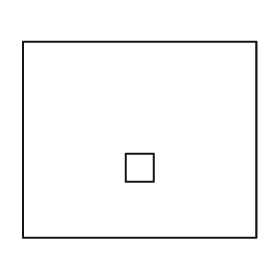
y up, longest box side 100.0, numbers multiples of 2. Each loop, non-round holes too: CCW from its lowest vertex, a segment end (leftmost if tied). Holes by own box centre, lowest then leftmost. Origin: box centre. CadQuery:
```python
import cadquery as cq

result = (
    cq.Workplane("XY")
    .moveTo(-50.0, -42.0)
    .lineTo(50.0, -42.0)
    .lineTo(50.0, 42.0)
    .lineTo(-50.0, 42.0)
    .close()
    .moveTo(-6.0, -18.0)
    .lineTo(6.0, -18.0)
    .lineTo(6.0, -6.0)
    .lineTo(-6.0, -6.0)
    .close()
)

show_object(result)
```